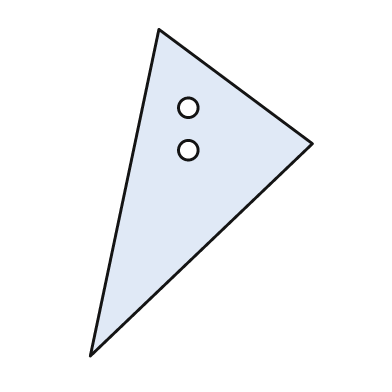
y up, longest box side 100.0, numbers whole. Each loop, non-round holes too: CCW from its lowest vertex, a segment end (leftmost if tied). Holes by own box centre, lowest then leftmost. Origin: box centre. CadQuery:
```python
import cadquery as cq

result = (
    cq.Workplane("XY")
    .moveTo(-34.0, -50.0)
    .lineTo(34.0, 15.0)
    .lineTo(-13.0, 50.0)
    .close()
    .moveTo(-4.0, 13.0)
    .circle(3.0)
    .moveTo(-4.0, 26.0)
    .circle(3.0)
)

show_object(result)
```